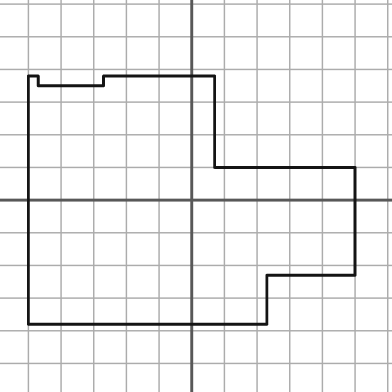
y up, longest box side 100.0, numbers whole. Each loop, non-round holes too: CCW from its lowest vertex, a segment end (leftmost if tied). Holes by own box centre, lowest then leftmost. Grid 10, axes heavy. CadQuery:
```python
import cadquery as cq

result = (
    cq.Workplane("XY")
    .moveTo(-50.0, -38.0)
    .lineTo(23.0, -38.0)
    .lineTo(23.0, -23.0)
    .lineTo(50.0, -23.0)
    .lineTo(50.0, 10.0)
    .lineTo(7.0, 10.0)
    .lineTo(7.0, 38.0)
    .lineTo(-27.0, 38.0)
    .lineTo(-27.0, 35.0)
    .lineTo(-47.0, 35.0)
    .lineTo(-47.0, 38.0)
    .lineTo(-50.0, 38.0)
    .close()
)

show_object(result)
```